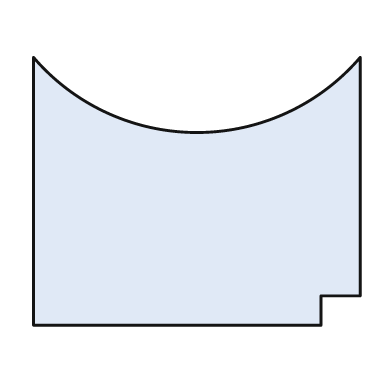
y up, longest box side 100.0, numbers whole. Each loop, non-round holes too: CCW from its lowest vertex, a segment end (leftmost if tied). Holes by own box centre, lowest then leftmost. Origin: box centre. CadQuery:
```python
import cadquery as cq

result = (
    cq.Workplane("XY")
    .moveTo(-50.0, -41.0)
    .lineTo(38.0, -41.0)
    .lineTo(38.0, -32.0)
    .lineTo(50.0, -32.0)
    .lineTo(50.0, 41.0)
    .threePointArc((0.0, 18.0), (-50.0, 41.0))
    .close()
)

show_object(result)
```